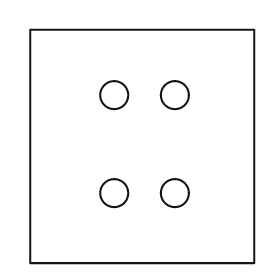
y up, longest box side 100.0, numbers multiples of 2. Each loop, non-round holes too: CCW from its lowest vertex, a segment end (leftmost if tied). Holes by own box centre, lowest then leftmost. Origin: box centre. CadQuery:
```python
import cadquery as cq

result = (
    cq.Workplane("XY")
    .moveTo(-48.0, -50.0)
    .lineTo(48.0, -50.0)
    .lineTo(48.0, 50.0)
    .lineTo(-48.0, 50.0)
    .close()
    .moveTo(-12.0, -20.0)
    .circle(6.0)
    .moveTo(14.0, -20.0)
    .circle(6.0)
    .moveTo(-12.0, 22.0)
    .circle(6.0)
    .moveTo(14.0, 22.0)
    .circle(6.0)
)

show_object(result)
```